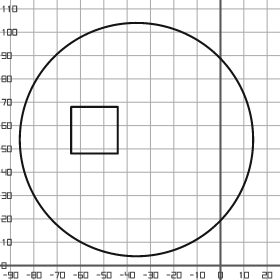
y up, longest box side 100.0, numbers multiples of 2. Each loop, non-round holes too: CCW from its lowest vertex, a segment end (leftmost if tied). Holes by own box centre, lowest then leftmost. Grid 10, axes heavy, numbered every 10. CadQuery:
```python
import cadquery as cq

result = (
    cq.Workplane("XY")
    .moveTo(-36.0, 54.0)
    .circle(50.0)
    .moveTo(-64.0, 48.0)
    .lineTo(-44.0, 48.0)
    .lineTo(-44.0, 68.0)
    .lineTo(-64.0, 68.0)
    .close()
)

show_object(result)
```